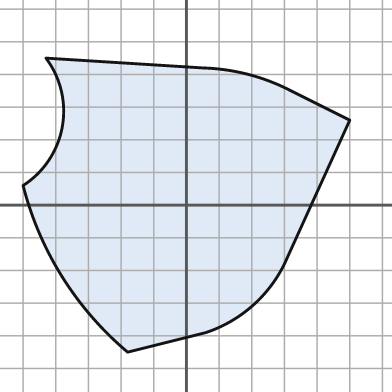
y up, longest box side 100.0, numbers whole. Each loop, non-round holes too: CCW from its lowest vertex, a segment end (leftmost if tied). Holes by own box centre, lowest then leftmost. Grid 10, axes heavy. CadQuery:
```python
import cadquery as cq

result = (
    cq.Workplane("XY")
    .moveTo(-18.0, -45.0)
    .lineTo(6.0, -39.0)
    .threePointArc((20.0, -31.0), (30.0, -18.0))
    .lineTo(50.0, 26.0)
    .lineTo(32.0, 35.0)
    .threePointArc((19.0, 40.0), (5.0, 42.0))
    .lineTo(-43.0, 45.0)
    .threePointArc((-38.0, 24.0), (-50.0, 6.0))
    .threePointArc((-38.0, -22.0), (-18.0, -45.0))
    .close()
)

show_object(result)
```